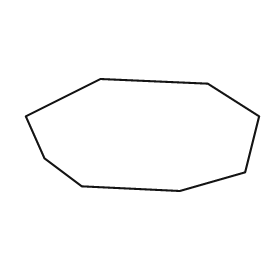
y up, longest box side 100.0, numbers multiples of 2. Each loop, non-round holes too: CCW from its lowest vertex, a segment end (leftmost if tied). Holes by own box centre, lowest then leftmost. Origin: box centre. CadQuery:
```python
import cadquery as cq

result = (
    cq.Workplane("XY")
    .moveTo(16.0, -24.0)
    .lineTo(44.0, -16.0)
    .lineTo(50.0, 8.0)
    .lineTo(28.0, 22.0)
    .lineTo(-18.0, 24.0)
    .lineTo(-50.0, 8.0)
    .lineTo(-42.0, -10.0)
    .lineTo(-26.0, -22.0)
    .close()
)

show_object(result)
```